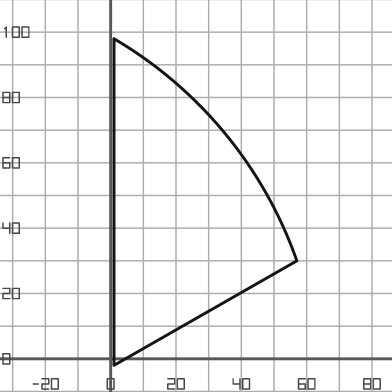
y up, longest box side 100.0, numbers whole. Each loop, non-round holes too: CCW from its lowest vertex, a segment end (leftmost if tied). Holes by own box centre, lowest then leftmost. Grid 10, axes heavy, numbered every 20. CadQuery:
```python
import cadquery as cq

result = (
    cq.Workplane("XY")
    .moveTo(1.0, -2.0)
    .lineTo(57.0, 30.0)
    .threePointArc((35.0, 69.0), (1.0, 98.0))
    .close()
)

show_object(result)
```